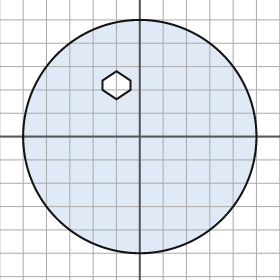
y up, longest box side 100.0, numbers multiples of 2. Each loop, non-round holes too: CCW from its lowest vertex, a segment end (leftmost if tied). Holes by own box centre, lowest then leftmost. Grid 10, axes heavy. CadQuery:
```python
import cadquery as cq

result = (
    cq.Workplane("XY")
    .moveTo(0.0, 0.0)
    .circle(50.0)
    .moveTo(-10.0, 16.0)
    .lineTo(-4.0, 20.0)
    .lineTo(-4.0, 24.0)
    .lineTo(-10.0, 28.0)
    .lineTo(-16.0, 24.0)
    .lineTo(-16.0, 20.0)
    .close()
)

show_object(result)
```